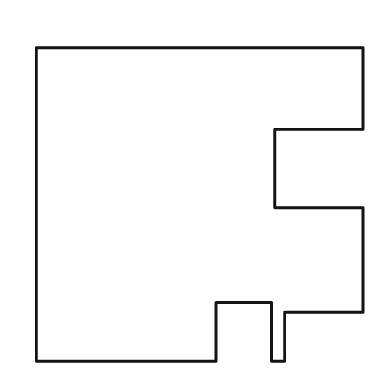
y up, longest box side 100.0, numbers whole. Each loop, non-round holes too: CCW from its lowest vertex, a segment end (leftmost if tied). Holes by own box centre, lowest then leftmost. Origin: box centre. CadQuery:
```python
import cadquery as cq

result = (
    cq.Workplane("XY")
    .moveTo(-50.0, -48.0)
    .lineTo(5.0, -48.0)
    .lineTo(5.0, -30.0)
    .lineTo(22.0, -30.0)
    .lineTo(22.0, -48.0)
    .lineTo(26.0, -48.0)
    .lineTo(26.0, -33.0)
    .lineTo(50.0, -33.0)
    .lineTo(50.0, -1.0)
    .lineTo(23.0, -1.0)
    .lineTo(23.0, 23.0)
    .lineTo(50.0, 23.0)
    .lineTo(50.0, 48.0)
    .lineTo(-50.0, 48.0)
    .close()
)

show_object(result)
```